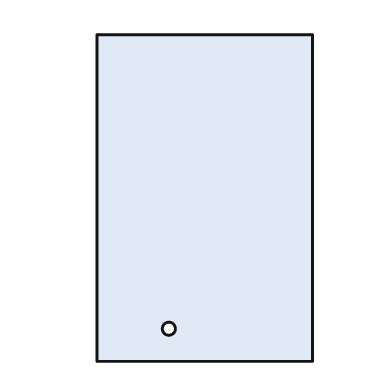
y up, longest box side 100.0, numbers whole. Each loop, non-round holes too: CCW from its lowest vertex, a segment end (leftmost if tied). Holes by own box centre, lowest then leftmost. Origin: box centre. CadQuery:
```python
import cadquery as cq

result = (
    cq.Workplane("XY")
    .moveTo(-33.0, -50.0)
    .lineTo(33.0, -50.0)
    .lineTo(33.0, 50.0)
    .lineTo(-33.0, 50.0)
    .close()
    .moveTo(-11.0, -40.0)
    .circle(2.0)
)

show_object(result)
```